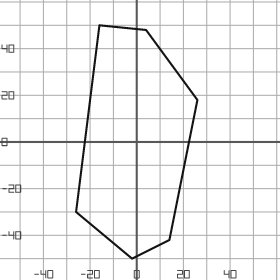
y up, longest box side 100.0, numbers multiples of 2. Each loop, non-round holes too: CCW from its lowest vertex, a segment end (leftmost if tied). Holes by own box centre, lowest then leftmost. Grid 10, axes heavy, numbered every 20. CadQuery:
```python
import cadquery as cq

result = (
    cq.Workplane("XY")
    .moveTo(-2.0, -50.0)
    .lineTo(14.0, -42.0)
    .lineTo(26.0, 18.0)
    .lineTo(4.0, 48.0)
    .lineTo(-16.0, 50.0)
    .lineTo(-26.0, -30.0)
    .close()
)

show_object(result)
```